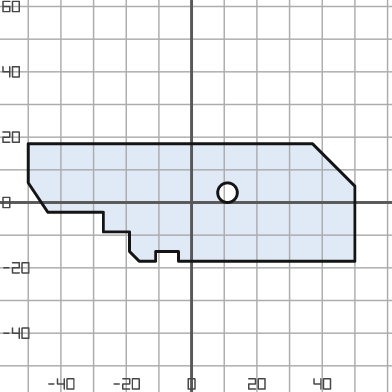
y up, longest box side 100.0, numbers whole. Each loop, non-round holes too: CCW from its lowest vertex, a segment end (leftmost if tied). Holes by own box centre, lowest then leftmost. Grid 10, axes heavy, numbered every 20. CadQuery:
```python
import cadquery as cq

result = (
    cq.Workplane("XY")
    .moveTo(-16.0, -18.0)
    .lineTo(-11.0, -18.0)
    .lineTo(-11.0, -15.0)
    .lineTo(-4.0, -15.0)
    .lineTo(-4.0, -18.0)
    .lineTo(50.0, -18.0)
    .lineTo(50.0, 5.0)
    .lineTo(37.0, 18.0)
    .lineTo(-50.0, 18.0)
    .lineTo(-50.0, 6.0)
    .lineTo(-44.0, -3.0)
    .lineTo(-27.0, -3.0)
    .lineTo(-27.0, -9.0)
    .lineTo(-19.0, -9.0)
    .lineTo(-19.0, -15.0)
    .close()
    .moveTo(11.0, 3.0)
    .circle(3.0)
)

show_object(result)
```